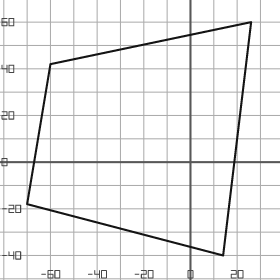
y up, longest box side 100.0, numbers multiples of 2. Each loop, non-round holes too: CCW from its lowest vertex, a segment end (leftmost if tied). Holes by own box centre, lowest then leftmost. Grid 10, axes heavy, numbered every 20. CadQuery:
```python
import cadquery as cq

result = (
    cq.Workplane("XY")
    .moveTo(14.0, -40.0)
    .lineTo(26.0, 60.0)
    .lineTo(-60.0, 42.0)
    .lineTo(-70.0, -18.0)
    .close()
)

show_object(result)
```